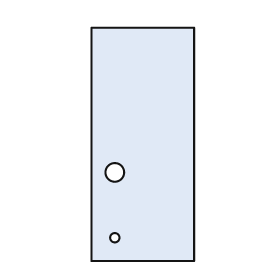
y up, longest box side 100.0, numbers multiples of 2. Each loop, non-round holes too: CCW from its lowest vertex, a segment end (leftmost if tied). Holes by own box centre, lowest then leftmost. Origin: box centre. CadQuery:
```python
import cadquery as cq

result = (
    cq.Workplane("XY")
    .moveTo(-22.0, -50.0)
    .lineTo(22.0, -50.0)
    .lineTo(22.0, 50.0)
    .lineTo(-22.0, 50.0)
    .close()
    .moveTo(-12.0, -40.0)
    .circle(2.0)
    .moveTo(-12.0, -12.0)
    .circle(4.0)
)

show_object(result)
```